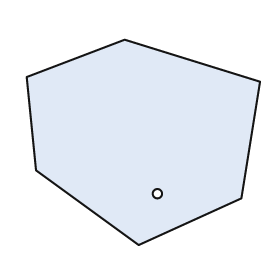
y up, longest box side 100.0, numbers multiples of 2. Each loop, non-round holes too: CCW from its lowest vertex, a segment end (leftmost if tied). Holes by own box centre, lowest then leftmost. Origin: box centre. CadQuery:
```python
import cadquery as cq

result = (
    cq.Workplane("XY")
    .moveTo(-2.0, -44.0)
    .lineTo(42.0, -24.0)
    .lineTo(50.0, 26.0)
    .lineTo(-8.0, 44.0)
    .lineTo(-50.0, 28.0)
    .lineTo(-46.0, -12.0)
    .close()
    .moveTo(6.0, -22.0)
    .circle(2.0)
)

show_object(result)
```